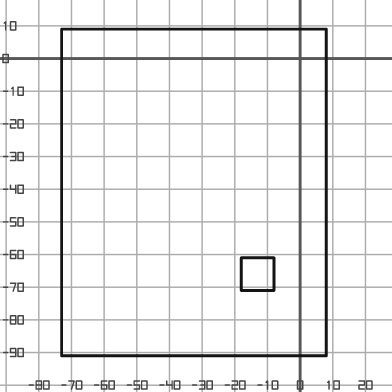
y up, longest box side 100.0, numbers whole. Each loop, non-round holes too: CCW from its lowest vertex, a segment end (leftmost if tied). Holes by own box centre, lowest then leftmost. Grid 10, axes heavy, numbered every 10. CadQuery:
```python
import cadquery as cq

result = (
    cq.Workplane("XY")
    .moveTo(-73.0, -91.0)
    .lineTo(8.0, -91.0)
    .lineTo(8.0, 9.0)
    .lineTo(-73.0, 9.0)
    .close()
    .moveTo(-18.0, -71.0)
    .lineTo(-8.0, -71.0)
    .lineTo(-8.0, -61.0)
    .lineTo(-18.0, -61.0)
    .close()
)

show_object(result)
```